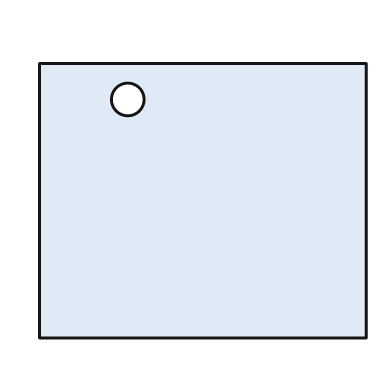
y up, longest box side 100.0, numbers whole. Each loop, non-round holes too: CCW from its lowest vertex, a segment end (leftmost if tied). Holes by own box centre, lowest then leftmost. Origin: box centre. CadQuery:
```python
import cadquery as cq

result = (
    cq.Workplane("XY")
    .moveTo(-50.0, -42.0)
    .lineTo(50.0, -42.0)
    .lineTo(50.0, 42.0)
    .lineTo(-50.0, 42.0)
    .close()
    .moveTo(-23.0, 31.0)
    .circle(5.0)
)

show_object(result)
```